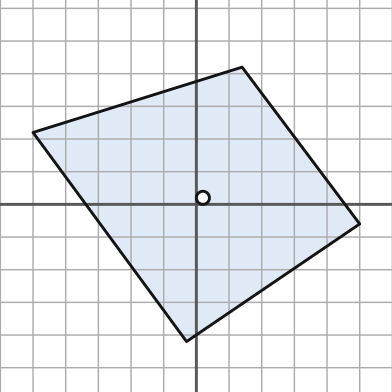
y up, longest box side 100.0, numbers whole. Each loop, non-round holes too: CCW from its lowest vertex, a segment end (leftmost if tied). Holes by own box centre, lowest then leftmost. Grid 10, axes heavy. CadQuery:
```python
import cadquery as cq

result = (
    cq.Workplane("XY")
    .moveTo(-3.0, -42.0)
    .lineTo(50.0, -6.0)
    .lineTo(14.0, 42.0)
    .lineTo(-50.0, 22.0)
    .close()
    .moveTo(2.0, 2.0)
    .circle(2.0)
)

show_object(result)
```